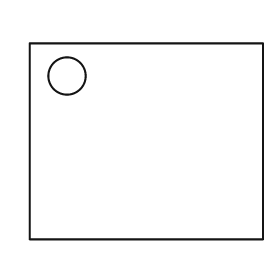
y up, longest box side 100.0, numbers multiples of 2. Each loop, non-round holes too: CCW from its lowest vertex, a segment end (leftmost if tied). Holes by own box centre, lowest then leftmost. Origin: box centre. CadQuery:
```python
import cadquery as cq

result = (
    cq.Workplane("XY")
    .moveTo(-50.0, -42.0)
    .lineTo(50.0, -42.0)
    .lineTo(50.0, 42.0)
    .lineTo(-50.0, 42.0)
    .close()
    .moveTo(-34.0, 28.0)
    .circle(8.0)
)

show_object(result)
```